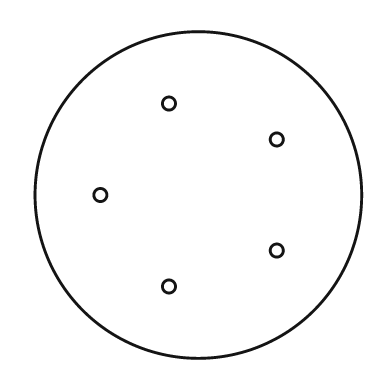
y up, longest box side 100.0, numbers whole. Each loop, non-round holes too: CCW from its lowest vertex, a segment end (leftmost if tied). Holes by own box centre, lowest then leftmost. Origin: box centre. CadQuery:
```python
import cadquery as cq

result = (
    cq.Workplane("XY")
    .moveTo(0.0, 0.0)
    .circle(50.0)
    .moveTo(-9.0, -28.0)
    .circle(2.0)
    .moveTo(24.0, -17.0)
    .circle(2.0)
    .moveTo(-30.0, 0.0)
    .circle(2.0)
    .moveTo(24.0, 17.0)
    .circle(2.0)
    .moveTo(-9.0, 28.0)
    .circle(2.0)
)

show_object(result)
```